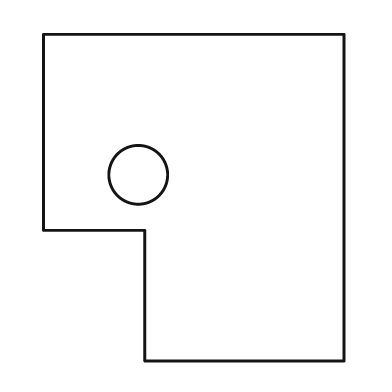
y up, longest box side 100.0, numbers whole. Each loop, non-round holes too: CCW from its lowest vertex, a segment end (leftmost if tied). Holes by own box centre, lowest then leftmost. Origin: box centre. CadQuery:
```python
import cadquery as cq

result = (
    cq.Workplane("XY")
    .moveTo(-15.0, -50.0)
    .lineTo(46.0, -50.0)
    .lineTo(46.0, 50.0)
    .lineTo(-46.0, 50.0)
    .lineTo(-46.0, -10.0)
    .lineTo(-15.0, -10.0)
    .close()
    .moveTo(-17.0, 7.0)
    .circle(9.0)
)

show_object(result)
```